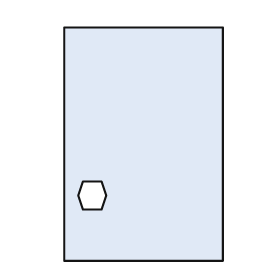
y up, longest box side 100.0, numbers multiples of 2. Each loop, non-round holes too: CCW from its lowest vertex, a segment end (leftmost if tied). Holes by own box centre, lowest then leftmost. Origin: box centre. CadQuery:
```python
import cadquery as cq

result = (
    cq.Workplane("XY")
    .moveTo(-34.0, -50.0)
    .lineTo(34.0, -50.0)
    .lineTo(34.0, 50.0)
    .lineTo(-34.0, 50.0)
    .close()
    .moveTo(-26.0, -28.0)
    .lineTo(-18.0, -28.0)
    .lineTo(-16.0, -22.0)
    .lineTo(-18.0, -16.0)
    .lineTo(-26.0, -16.0)
    .lineTo(-28.0, -22.0)
    .close()
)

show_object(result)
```